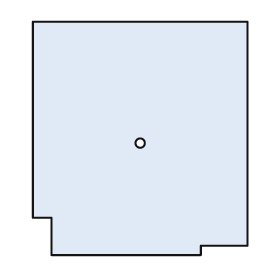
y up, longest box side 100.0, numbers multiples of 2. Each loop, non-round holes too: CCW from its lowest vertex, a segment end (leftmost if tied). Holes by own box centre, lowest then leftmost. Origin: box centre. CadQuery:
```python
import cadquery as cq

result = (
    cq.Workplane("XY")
    .moveTo(-38.0, -50.0)
    .lineTo(26.0, -50.0)
    .lineTo(26.0, -46.0)
    .lineTo(46.0, -46.0)
    .lineTo(46.0, 50.0)
    .lineTo(-46.0, 50.0)
    .lineTo(-46.0, -34.0)
    .lineTo(-38.0, -34.0)
    .close()
    .moveTo(0.0, -2.0)
    .circle(2.0)
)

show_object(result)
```